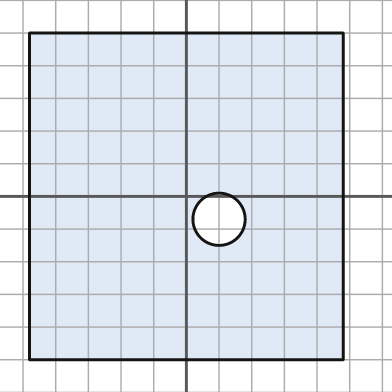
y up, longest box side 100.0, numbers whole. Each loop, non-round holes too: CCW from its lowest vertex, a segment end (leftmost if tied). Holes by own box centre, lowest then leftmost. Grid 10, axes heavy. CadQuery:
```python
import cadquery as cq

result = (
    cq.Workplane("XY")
    .moveTo(-48.0, -50.0)
    .lineTo(48.0, -50.0)
    .lineTo(48.0, 50.0)
    .lineTo(-48.0, 50.0)
    .close()
    .moveTo(10.0, -7.0)
    .circle(8.0)
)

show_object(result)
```